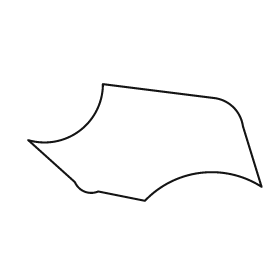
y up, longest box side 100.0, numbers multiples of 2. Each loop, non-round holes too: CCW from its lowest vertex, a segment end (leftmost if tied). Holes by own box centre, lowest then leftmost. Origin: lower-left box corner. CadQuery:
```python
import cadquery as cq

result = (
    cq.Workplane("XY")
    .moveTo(50.0, 0.0)
    .threePointArc((74.0, 12.0), (100.0, 6.0))
    .lineTo(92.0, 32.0)
    .threePointArc((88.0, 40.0), (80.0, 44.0))
    .lineTo(32.0, 50.0)
    .threePointArc((22.0, 30.0), (0.0, 26.0))
    .lineTo(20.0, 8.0)
    .threePointArc((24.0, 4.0), (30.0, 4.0))
    .close()
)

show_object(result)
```